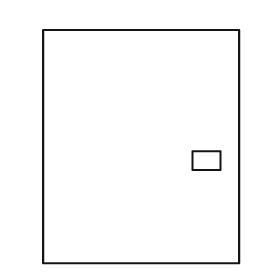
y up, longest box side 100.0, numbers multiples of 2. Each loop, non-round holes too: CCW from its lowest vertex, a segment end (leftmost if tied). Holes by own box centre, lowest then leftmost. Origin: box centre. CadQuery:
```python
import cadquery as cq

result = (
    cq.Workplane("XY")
    .moveTo(-42.0, -50.0)
    .lineTo(42.0, -50.0)
    .lineTo(42.0, 50.0)
    .lineTo(-42.0, 50.0)
    .close()
    .moveTo(22.0, -10.0)
    .lineTo(34.0, -10.0)
    .lineTo(34.0, -2.0)
    .lineTo(22.0, -2.0)
    .close()
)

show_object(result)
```